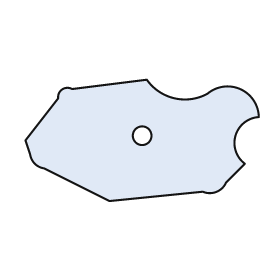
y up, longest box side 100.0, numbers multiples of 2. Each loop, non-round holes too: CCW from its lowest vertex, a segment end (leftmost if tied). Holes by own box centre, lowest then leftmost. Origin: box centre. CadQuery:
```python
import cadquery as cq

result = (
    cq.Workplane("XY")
    .moveTo(-14.0, -26.0)
    .lineTo(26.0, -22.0)
    .threePointArc((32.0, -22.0), (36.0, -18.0))
    .lineTo(44.0, -10.0)
    .threePointArc((40.0, 2.0), (50.0, 10.0))
    .threePointArc((42.0, 22.0), (28.0, 20.0))
    .threePointArc((14.0, 18.0), (2.0, 26.0))
    .lineTo(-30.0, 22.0)
    .threePointArc((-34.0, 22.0), (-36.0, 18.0))
    .lineTo(-50.0, 0.0)
    .lineTo(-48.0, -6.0)
    .threePointArc((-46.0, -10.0), (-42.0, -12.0))
    .close()
    .moveTo(0.0, 2.0)
    .circle(4.0)
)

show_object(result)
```